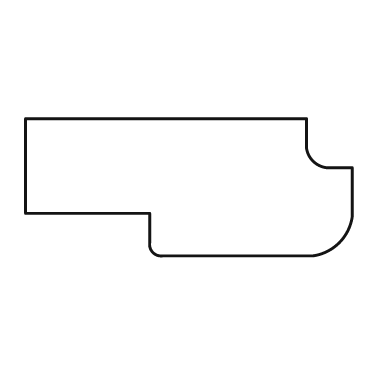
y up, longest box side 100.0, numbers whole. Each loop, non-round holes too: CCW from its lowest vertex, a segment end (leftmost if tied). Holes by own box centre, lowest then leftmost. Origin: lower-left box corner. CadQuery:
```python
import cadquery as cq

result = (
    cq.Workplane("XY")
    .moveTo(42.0, 0.0)
    .lineTo(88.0, 0.0)
    .threePointArc((96.0, 4.0), (100.0, 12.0))
    .lineTo(100.0, 27.0)
    .lineTo(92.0, 27.0)
    .threePointArc((88.0, 29.0), (86.0, 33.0))
    .lineTo(86.0, 42.0)
    .lineTo(0.0, 42.0)
    .lineTo(0.0, 13.0)
    .lineTo(38.0, 13.0)
    .lineTo(38.0, 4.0)
    .threePointArc((39.0, 1.0), (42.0, 0.0))
    .close()
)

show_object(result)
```